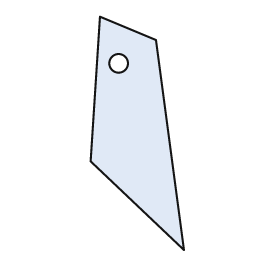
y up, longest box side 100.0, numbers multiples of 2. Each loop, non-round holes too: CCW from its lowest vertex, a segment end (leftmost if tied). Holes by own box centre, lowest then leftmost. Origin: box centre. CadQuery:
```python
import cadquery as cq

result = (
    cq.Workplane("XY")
    .moveTo(20.0, -50.0)
    .lineTo(8.0, 40.0)
    .lineTo(-16.0, 50.0)
    .lineTo(-20.0, -12.0)
    .close()
    .moveTo(-8.0, 30.0)
    .circle(4.0)
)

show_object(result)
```